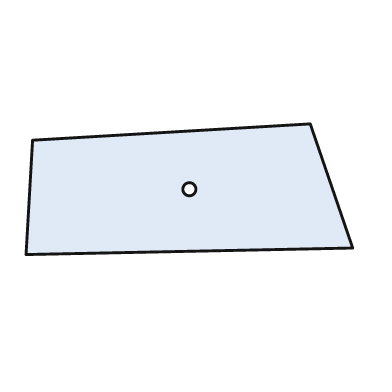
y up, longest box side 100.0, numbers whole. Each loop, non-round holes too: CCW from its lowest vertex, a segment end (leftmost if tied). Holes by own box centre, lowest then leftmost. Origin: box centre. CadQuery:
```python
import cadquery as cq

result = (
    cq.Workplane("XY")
    .moveTo(-50.0, -20.0)
    .lineTo(50.0, -18.0)
    .lineTo(37.0, 20.0)
    .lineTo(-48.0, 15.0)
    .close()
    .moveTo(0.0, 0.0)
    .circle(2.0)
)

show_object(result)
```